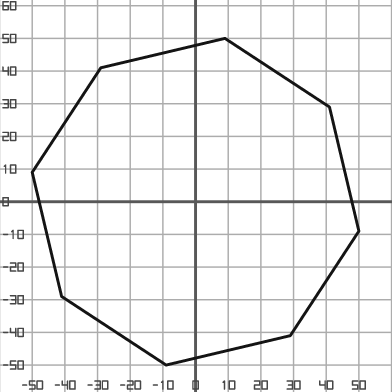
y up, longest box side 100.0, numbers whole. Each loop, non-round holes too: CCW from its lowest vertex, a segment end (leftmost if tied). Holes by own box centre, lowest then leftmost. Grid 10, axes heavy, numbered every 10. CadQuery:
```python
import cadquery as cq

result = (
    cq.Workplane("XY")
    .moveTo(-9.0, -50.0)
    .lineTo(29.0, -41.0)
    .lineTo(50.0, -9.0)
    .lineTo(41.0, 29.0)
    .lineTo(9.0, 50.0)
    .lineTo(-29.0, 41.0)
    .lineTo(-50.0, 9.0)
    .lineTo(-41.0, -29.0)
    .close()
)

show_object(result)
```